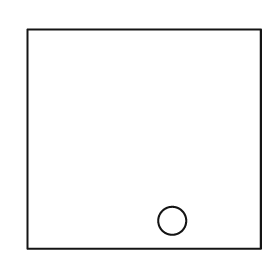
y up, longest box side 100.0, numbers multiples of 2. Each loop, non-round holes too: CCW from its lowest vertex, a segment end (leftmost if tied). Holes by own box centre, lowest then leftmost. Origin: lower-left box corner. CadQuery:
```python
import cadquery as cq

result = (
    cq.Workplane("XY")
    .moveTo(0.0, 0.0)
    .lineTo(100.0, 0.0)
    .lineTo(100.0, 94.0)
    .lineTo(0.0, 94.0)
    .close()
    .moveTo(62.0, 12.0)
    .circle(6.0)
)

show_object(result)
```